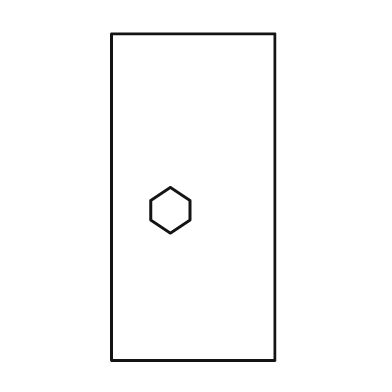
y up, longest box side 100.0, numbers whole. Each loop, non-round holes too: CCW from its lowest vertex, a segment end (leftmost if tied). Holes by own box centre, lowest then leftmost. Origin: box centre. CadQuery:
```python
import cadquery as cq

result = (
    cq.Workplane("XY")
    .moveTo(-25.0, -50.0)
    .lineTo(25.0, -50.0)
    .lineTo(25.0, 50.0)
    .lineTo(-25.0, 50.0)
    .close()
    .moveTo(-7.0, -11.0)
    .lineTo(-1.0, -7.0)
    .lineTo(-1.0, -1.0)
    .lineTo(-7.0, 3.0)
    .lineTo(-13.0, -1.0)
    .lineTo(-13.0, -7.0)
    .close()
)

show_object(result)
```